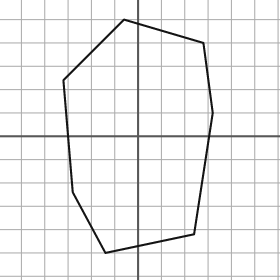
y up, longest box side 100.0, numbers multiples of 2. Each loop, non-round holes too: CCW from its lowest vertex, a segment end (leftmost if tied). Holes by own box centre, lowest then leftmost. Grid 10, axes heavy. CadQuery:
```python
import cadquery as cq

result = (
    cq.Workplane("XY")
    .moveTo(-14.0, -50.0)
    .lineTo(24.0, -42.0)
    .lineTo(32.0, 10.0)
    .lineTo(28.0, 40.0)
    .lineTo(-6.0, 50.0)
    .lineTo(-32.0, 24.0)
    .lineTo(-28.0, -24.0)
    .close()
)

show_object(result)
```